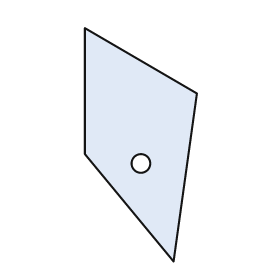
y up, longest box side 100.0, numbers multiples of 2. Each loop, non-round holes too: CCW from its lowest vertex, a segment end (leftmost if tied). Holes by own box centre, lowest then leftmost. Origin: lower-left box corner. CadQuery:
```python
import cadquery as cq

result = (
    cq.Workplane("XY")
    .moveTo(38.0, 0.0)
    .lineTo(48.0, 72.0)
    .lineTo(0.0, 100.0)
    .lineTo(0.0, 46.0)
    .close()
    .moveTo(24.0, 42.0)
    .circle(4.0)
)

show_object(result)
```